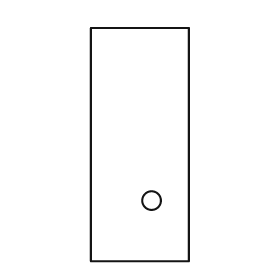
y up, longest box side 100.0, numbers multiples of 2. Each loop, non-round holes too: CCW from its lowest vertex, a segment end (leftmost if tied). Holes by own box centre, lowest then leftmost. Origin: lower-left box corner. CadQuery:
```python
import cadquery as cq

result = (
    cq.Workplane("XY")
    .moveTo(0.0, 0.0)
    .lineTo(42.0, 0.0)
    .lineTo(42.0, 100.0)
    .lineTo(0.0, 100.0)
    .close()
    .moveTo(26.0, 26.0)
    .circle(4.0)
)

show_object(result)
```